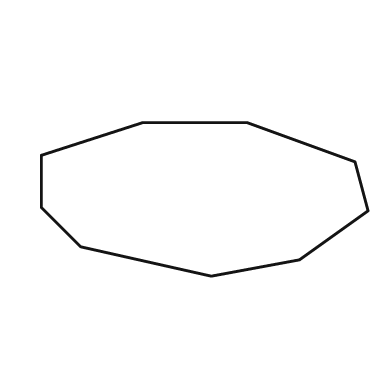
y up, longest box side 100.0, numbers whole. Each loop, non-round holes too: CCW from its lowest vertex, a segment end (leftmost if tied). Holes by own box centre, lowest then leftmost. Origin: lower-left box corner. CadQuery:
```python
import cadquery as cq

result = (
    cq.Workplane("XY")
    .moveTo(52.0, 0.0)
    .lineTo(79.0, 5.0)
    .lineTo(100.0, 20.0)
    .lineTo(96.0, 35.0)
    .lineTo(63.0, 47.0)
    .lineTo(31.0, 47.0)
    .lineTo(0.0, 37.0)
    .lineTo(0.0, 21.0)
    .lineTo(12.0, 9.0)
    .close()
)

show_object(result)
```